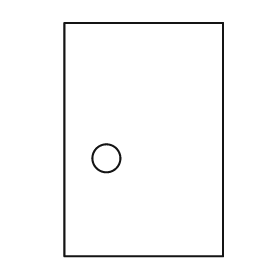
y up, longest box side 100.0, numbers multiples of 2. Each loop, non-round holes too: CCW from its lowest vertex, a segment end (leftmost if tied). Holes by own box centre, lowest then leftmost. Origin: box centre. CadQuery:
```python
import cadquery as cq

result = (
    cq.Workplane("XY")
    .moveTo(-34.0, -50.0)
    .lineTo(34.0, -50.0)
    .lineTo(34.0, 50.0)
    .lineTo(-34.0, 50.0)
    .close()
    .moveTo(-16.0, -8.0)
    .circle(6.0)
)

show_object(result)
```